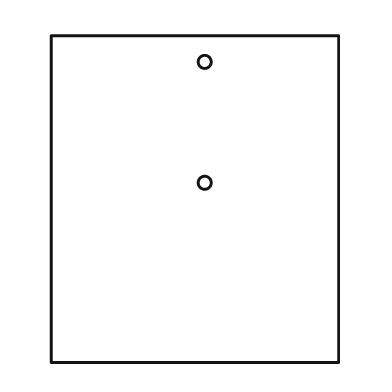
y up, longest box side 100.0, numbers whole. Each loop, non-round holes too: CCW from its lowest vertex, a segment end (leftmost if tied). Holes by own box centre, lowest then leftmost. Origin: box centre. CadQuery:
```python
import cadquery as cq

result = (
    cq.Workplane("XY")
    .moveTo(-44.0, -50.0)
    .lineTo(44.0, -50.0)
    .lineTo(44.0, 50.0)
    .lineTo(-44.0, 50.0)
    .close()
    .moveTo(3.0, 5.0)
    .circle(2.0)
    .moveTo(3.0, 42.0)
    .circle(2.0)
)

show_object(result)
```